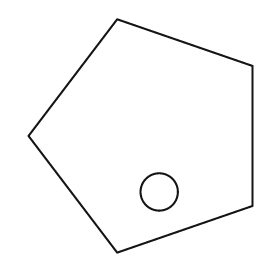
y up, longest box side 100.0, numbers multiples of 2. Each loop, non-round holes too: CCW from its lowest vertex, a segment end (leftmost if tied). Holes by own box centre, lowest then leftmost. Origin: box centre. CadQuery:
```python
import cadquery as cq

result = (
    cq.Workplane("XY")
    .moveTo(-10.0, -50.0)
    .lineTo(48.0, -30.0)
    .lineTo(48.0, 30.0)
    .lineTo(-10.0, 50.0)
    .lineTo(-48.0, 0.0)
    .close()
    .moveTo(8.0, -24.0)
    .circle(8.0)
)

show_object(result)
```